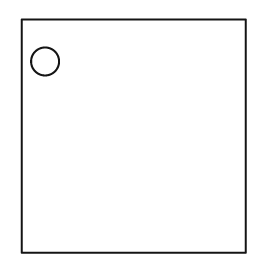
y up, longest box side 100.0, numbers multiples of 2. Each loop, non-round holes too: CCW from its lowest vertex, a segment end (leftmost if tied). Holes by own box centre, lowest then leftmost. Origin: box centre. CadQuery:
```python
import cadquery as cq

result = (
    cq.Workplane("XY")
    .moveTo(-48.0, -50.0)
    .lineTo(48.0, -50.0)
    .lineTo(48.0, 50.0)
    .lineTo(-48.0, 50.0)
    .close()
    .moveTo(-38.0, 32.0)
    .circle(6.0)
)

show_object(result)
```